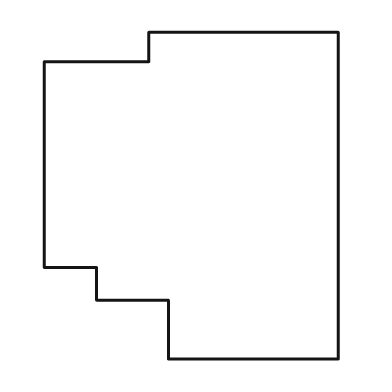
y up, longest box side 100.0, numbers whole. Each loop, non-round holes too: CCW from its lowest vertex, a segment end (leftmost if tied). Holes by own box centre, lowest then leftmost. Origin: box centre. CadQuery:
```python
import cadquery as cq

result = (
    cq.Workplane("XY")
    .moveTo(-7.0, -50.0)
    .lineTo(45.0, -50.0)
    .lineTo(45.0, 50.0)
    .lineTo(-13.0, 50.0)
    .lineTo(-13.0, 41.0)
    .lineTo(-45.0, 41.0)
    .lineTo(-45.0, -22.0)
    .lineTo(-29.0, -22.0)
    .lineTo(-29.0, -32.0)
    .lineTo(-7.0, -32.0)
    .close()
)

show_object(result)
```